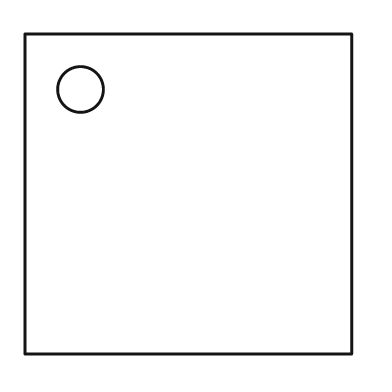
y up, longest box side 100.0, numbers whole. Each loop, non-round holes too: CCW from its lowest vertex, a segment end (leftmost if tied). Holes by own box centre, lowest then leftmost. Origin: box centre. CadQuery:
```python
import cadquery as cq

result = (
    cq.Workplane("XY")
    .moveTo(-50.0, -49.0)
    .lineTo(50.0, -49.0)
    .lineTo(50.0, 49.0)
    .lineTo(-50.0, 49.0)
    .close()
    .moveTo(-33.0, 32.0)
    .circle(7.0)
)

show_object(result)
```